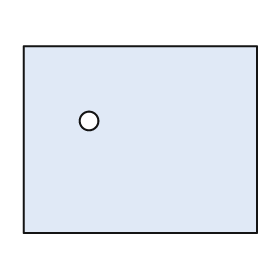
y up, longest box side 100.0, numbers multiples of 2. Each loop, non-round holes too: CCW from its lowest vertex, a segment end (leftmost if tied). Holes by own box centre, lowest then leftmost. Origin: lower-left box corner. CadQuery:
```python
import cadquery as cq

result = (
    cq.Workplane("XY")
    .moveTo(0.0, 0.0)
    .lineTo(100.0, 0.0)
    .lineTo(100.0, 80.0)
    .lineTo(0.0, 80.0)
    .close()
    .moveTo(28.0, 48.0)
    .circle(4.0)
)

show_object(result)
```